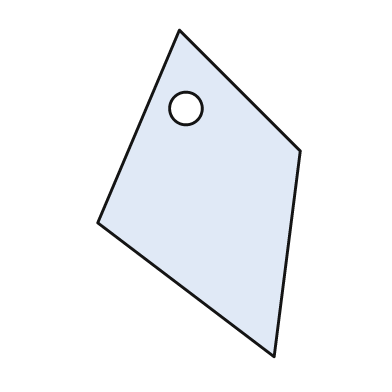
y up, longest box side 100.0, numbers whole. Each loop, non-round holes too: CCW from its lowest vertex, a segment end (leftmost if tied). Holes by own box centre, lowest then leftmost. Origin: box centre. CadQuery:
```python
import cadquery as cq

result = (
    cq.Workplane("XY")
    .moveTo(23.0, -50.0)
    .lineTo(31.0, 13.0)
    .lineTo(-6.0, 50.0)
    .lineTo(-31.0, -9.0)
    .close()
    .moveTo(-4.0, 26.0)
    .circle(5.0)
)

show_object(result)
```